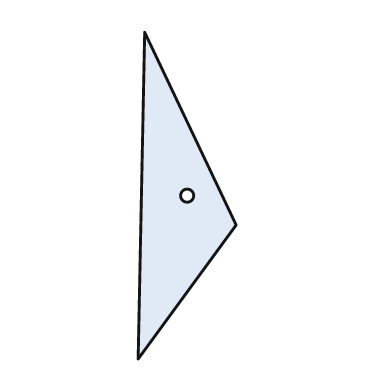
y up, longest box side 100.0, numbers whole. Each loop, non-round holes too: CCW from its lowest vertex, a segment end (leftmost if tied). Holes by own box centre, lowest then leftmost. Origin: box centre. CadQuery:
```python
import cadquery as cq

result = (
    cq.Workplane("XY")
    .moveTo(-15.0, -50.0)
    .lineTo(15.0, -9.0)
    .lineTo(-13.0, 50.0)
    .close()
    .moveTo(0.0, 0.0)
    .circle(2.0)
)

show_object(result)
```